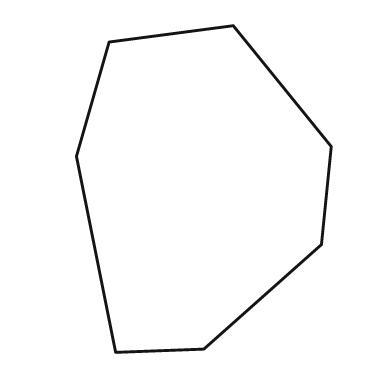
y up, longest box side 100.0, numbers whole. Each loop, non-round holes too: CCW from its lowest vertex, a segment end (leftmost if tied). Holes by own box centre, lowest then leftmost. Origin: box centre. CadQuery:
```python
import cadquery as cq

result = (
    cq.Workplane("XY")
    .moveTo(-27.0, -50.0)
    .lineTo(0.0, -49.0)
    .lineTo(36.0, -17.0)
    .lineTo(39.0, 13.0)
    .lineTo(9.0, 50.0)
    .lineTo(-29.0, 45.0)
    .lineTo(-39.0, 10.0)
    .close()
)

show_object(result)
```